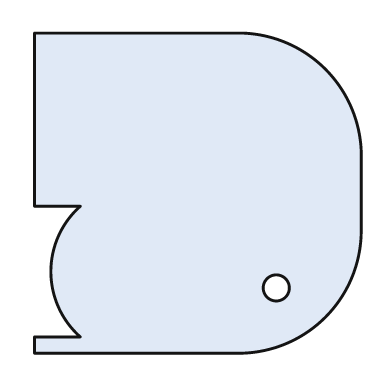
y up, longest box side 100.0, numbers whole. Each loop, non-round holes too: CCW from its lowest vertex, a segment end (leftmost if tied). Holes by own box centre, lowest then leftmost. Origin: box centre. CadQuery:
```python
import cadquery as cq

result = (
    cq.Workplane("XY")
    .moveTo(-50.0, -49.0)
    .lineTo(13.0, -49.0)
    .threePointArc((39.0, -38.0), (50.0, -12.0))
    .lineTo(50.0, 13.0)
    .threePointArc((39.0, 38.0), (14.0, 49.0))
    .lineTo(-50.0, 49.0)
    .lineTo(-50.0, -4.0)
    .lineTo(-36.0, -4.0)
    .threePointArc((-45.0, -24.0), (-36.0, -44.0))
    .lineTo(-50.0, -44.0)
    .close()
    .moveTo(24.0, -29.0)
    .circle(4.0)
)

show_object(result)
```